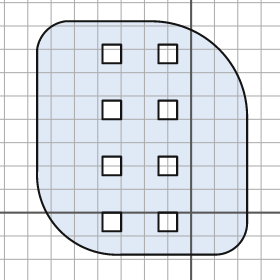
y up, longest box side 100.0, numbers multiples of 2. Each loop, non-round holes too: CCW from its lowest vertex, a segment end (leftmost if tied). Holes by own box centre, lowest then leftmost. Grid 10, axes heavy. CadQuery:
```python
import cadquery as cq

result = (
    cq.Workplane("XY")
    .moveTo(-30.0, -18.0)
    .lineTo(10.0, -18.0)
    .threePointArc((20.0, -14.0), (24.0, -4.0))
    .lineTo(24.0, 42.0)
    .threePointArc((12.0, 70.0), (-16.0, 82.0))
    .lineTo(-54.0, 82.0)
    .threePointArc((-62.0, 78.0), (-66.0, 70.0))
    .lineTo(-66.0, 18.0)
    .threePointArc((-56.0, -8.0), (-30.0, -18.0))
    .close()
    .moveTo(-38.0, -8.0)
    .lineTo(-30.0, -8.0)
    .lineTo(-30.0, 0.0)
    .lineTo(-38.0, 0.0)
    .close()
    .moveTo(-14.0, -8.0)
    .lineTo(-6.0, -8.0)
    .lineTo(-6.0, 0.0)
    .lineTo(-14.0, 0.0)
    .close()
    .moveTo(-38.0, 16.0)
    .lineTo(-30.0, 16.0)
    .lineTo(-30.0, 24.0)
    .lineTo(-38.0, 24.0)
    .close()
    .moveTo(-14.0, 16.0)
    .lineTo(-6.0, 16.0)
    .lineTo(-6.0, 24.0)
    .lineTo(-14.0, 24.0)
    .close()
    .moveTo(-38.0, 40.0)
    .lineTo(-30.0, 40.0)
    .lineTo(-30.0, 48.0)
    .lineTo(-38.0, 48.0)
    .close()
    .moveTo(-14.0, 40.0)
    .lineTo(-6.0, 40.0)
    .lineTo(-6.0, 48.0)
    .lineTo(-14.0, 48.0)
    .close()
    .moveTo(-38.0, 64.0)
    .lineTo(-30.0, 64.0)
    .lineTo(-30.0, 72.0)
    .lineTo(-38.0, 72.0)
    .close()
    .moveTo(-14.0, 64.0)
    .lineTo(-6.0, 64.0)
    .lineTo(-6.0, 72.0)
    .lineTo(-14.0, 72.0)
    .close()
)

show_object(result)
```